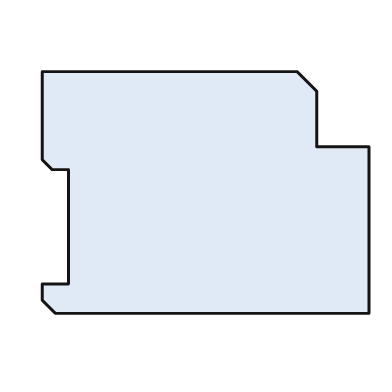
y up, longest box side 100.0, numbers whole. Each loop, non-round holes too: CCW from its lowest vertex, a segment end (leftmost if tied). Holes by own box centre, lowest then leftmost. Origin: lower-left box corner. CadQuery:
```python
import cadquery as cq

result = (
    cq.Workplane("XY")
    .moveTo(4.0, 0.0)
    .lineTo(100.0, 0.0)
    .lineTo(100.0, 51.0)
    .lineTo(84.0, 51.0)
    .lineTo(84.0, 68.0)
    .lineTo(78.0, 74.0)
    .lineTo(0.0, 74.0)
    .lineTo(0.0, 47.0)
    .lineTo(3.0, 44.0)
    .lineTo(8.0, 44.0)
    .lineTo(8.0, 9.0)
    .lineTo(0.0, 9.0)
    .lineTo(0.0, 4.0)
    .close()
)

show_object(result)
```